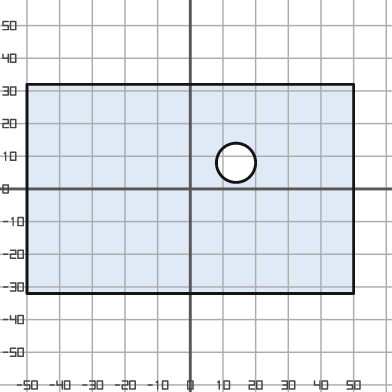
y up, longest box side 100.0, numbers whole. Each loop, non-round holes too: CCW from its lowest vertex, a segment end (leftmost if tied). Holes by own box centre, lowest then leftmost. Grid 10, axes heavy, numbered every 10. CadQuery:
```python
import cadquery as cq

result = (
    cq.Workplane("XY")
    .moveTo(-50.0, -32.0)
    .lineTo(50.0, -32.0)
    .lineTo(50.0, 32.0)
    .lineTo(-50.0, 32.0)
    .close()
    .moveTo(14.0, 8.0)
    .circle(6.0)
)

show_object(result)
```